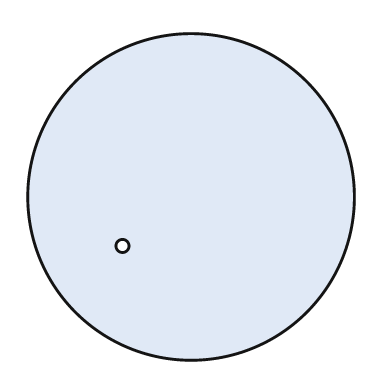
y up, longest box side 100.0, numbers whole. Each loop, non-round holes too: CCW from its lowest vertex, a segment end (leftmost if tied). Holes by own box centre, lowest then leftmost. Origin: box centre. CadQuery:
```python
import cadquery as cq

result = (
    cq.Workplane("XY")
    .moveTo(0.0, 0.0)
    .circle(50.0)
    .moveTo(-21.0, -15.0)
    .circle(2.0)
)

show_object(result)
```